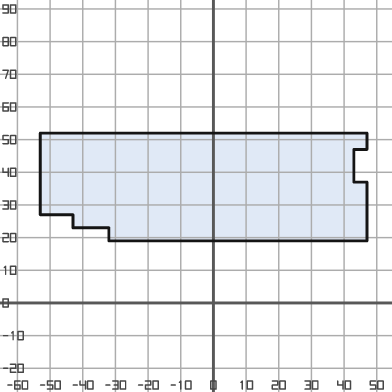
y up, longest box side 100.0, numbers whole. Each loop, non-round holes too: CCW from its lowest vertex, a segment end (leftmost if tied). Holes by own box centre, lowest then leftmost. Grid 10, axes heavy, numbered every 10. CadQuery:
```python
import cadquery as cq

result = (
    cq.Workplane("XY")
    .moveTo(-32.0, 19.0)
    .lineTo(47.0, 19.0)
    .lineTo(47.0, 37.0)
    .lineTo(43.0, 37.0)
    .lineTo(43.0, 47.0)
    .lineTo(47.0, 47.0)
    .lineTo(47.0, 52.0)
    .lineTo(-53.0, 52.0)
    .lineTo(-53.0, 27.0)
    .lineTo(-43.0, 27.0)
    .lineTo(-43.0, 23.0)
    .lineTo(-32.0, 23.0)
    .close()
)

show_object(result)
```